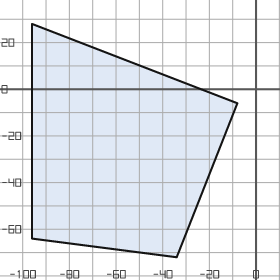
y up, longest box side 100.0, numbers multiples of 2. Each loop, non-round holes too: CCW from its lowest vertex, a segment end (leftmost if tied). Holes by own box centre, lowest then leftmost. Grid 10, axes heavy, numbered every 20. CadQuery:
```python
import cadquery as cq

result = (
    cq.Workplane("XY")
    .moveTo(-34.0, -72.0)
    .lineTo(-8.0, -6.0)
    .lineTo(-96.0, 28.0)
    .lineTo(-96.0, -64.0)
    .close()
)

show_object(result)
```